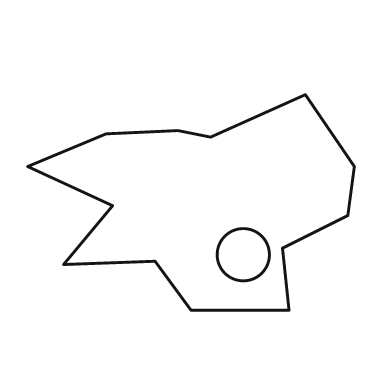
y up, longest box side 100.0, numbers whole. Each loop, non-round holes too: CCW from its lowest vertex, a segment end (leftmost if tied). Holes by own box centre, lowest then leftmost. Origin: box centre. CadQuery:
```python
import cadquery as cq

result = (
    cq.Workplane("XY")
    .moveTo(0.0, -33.0)
    .lineTo(30.0, -33.0)
    .lineTo(28.0, -14.0)
    .lineTo(48.0, -4.0)
    .lineTo(50.0, 11.0)
    .lineTo(35.0, 33.0)
    .lineTo(6.0, 20.0)
    .lineTo(-4.0, 22.0)
    .lineTo(-26.0, 21.0)
    .lineTo(-50.0, 11.0)
    .lineTo(-24.0, -1.0)
    .lineTo(-39.0, -19.0)
    .lineTo(-11.0, -18.0)
    .close()
    .moveTo(16.0, -16.0)
    .circle(8.0)
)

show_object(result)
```